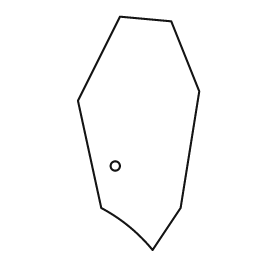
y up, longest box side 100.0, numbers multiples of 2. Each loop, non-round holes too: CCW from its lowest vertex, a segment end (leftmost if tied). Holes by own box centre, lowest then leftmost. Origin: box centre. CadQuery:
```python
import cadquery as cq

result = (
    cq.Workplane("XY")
    .moveTo(6.0, -50.0)
    .lineTo(18.0, -32.0)
    .lineTo(26.0, 18.0)
    .lineTo(14.0, 48.0)
    .lineTo(-8.0, 50.0)
    .lineTo(-26.0, 14.0)
    .lineTo(-16.0, -32.0)
    .threePointArc((-4.0, -40.0), (6.0, -50.0))
    .close()
    .moveTo(-10.0, -14.0)
    .circle(2.0)
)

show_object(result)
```